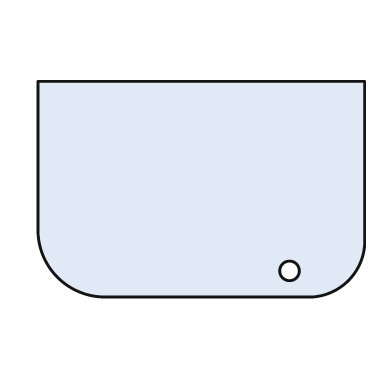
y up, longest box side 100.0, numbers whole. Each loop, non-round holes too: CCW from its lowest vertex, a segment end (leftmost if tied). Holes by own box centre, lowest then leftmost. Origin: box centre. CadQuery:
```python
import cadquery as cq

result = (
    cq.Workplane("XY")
    .moveTo(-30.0, -33.0)
    .lineTo(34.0, -33.0)
    .threePointArc((45.0, -28.0), (50.0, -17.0))
    .lineTo(50.0, 33.0)
    .lineTo(-50.0, 33.0)
    .lineTo(-50.0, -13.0)
    .threePointArc((-44.0, -27.0), (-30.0, -33.0))
    .close()
    .moveTo(27.0, -25.0)
    .circle(3.0)
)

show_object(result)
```